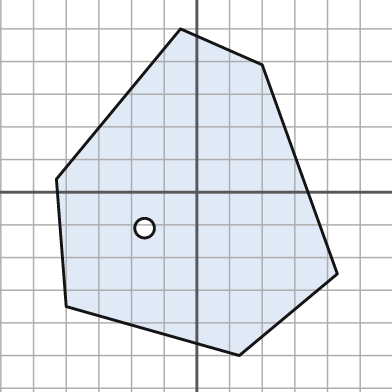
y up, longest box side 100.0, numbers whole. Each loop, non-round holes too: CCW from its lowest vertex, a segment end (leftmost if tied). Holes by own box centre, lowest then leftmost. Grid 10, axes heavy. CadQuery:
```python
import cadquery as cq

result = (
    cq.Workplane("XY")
    .moveTo(13.0, -50.0)
    .lineTo(43.0, -25.0)
    .lineTo(20.0, 39.0)
    .lineTo(-5.0, 50.0)
    .lineTo(-43.0, 4.0)
    .lineTo(-40.0, -35.0)
    .close()
    .moveTo(-16.0, -11.0)
    .circle(3.0)
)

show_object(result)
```